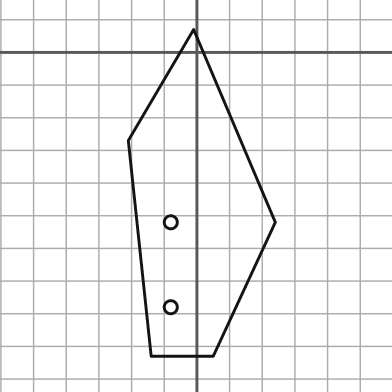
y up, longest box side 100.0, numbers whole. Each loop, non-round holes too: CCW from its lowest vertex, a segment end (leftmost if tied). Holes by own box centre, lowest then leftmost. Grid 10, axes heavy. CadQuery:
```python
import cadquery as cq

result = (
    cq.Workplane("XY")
    .moveTo(-14.0, -93.0)
    .lineTo(5.0, -93.0)
    .lineTo(24.0, -52.0)
    .lineTo(-1.0, 7.0)
    .lineTo(-21.0, -27.0)
    .close()
    .moveTo(-8.0, -78.0)
    .circle(2.0)
    .moveTo(-8.0, -52.0)
    .circle(2.0)
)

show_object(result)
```